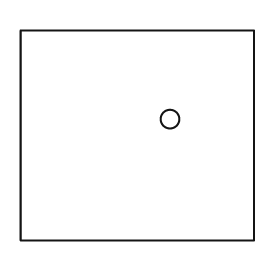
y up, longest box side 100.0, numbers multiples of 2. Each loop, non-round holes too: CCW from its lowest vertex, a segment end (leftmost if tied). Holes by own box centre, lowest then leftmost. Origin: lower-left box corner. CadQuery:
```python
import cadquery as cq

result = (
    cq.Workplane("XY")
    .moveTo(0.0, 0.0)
    .lineTo(100.0, 0.0)
    .lineTo(100.0, 90.0)
    .lineTo(0.0, 90.0)
    .close()
    .moveTo(64.0, 52.0)
    .circle(4.0)
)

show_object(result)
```